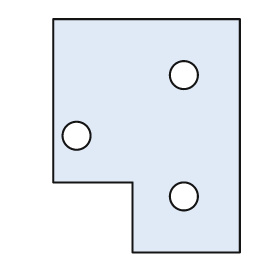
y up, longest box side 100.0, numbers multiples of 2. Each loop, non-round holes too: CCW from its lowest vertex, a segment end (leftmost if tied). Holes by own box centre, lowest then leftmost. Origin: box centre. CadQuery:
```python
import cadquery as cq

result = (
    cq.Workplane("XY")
    .moveTo(-6.0, -50.0)
    .lineTo(40.0, -50.0)
    .lineTo(40.0, 50.0)
    .lineTo(-40.0, 50.0)
    .lineTo(-40.0, -20.0)
    .lineTo(-6.0, -20.0)
    .close()
    .moveTo(16.0, -26.0)
    .circle(6.0)
    .moveTo(-30.0, 0.0)
    .circle(6.0)
    .moveTo(16.0, 26.0)
    .circle(6.0)
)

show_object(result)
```